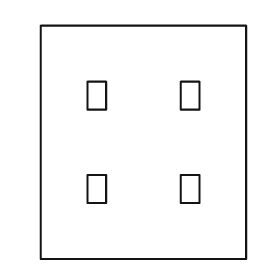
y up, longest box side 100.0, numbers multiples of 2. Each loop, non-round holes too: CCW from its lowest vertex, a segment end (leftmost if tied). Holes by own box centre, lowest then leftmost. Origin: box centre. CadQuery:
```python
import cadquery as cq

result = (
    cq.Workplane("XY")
    .moveTo(-44.0, -50.0)
    .lineTo(44.0, -50.0)
    .lineTo(44.0, 50.0)
    .lineTo(-44.0, 50.0)
    .close()
    .moveTo(-24.0, -26.0)
    .lineTo(-16.0, -26.0)
    .lineTo(-16.0, -14.0)
    .lineTo(-24.0, -14.0)
    .close()
    .moveTo(16.0, -26.0)
    .lineTo(24.0, -26.0)
    .lineTo(24.0, -14.0)
    .lineTo(16.0, -14.0)
    .close()
    .moveTo(-24.0, 14.0)
    .lineTo(-16.0, 14.0)
    .lineTo(-16.0, 26.0)
    .lineTo(-24.0, 26.0)
    .close()
    .moveTo(16.0, 14.0)
    .lineTo(24.0, 14.0)
    .lineTo(24.0, 26.0)
    .lineTo(16.0, 26.0)
    .close()
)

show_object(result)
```